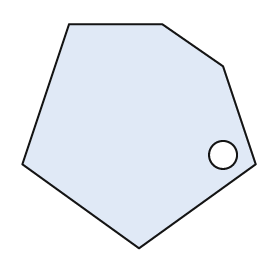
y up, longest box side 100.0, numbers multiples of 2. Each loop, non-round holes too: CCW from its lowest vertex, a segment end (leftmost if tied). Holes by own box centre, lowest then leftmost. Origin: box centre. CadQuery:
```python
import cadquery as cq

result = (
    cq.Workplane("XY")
    .moveTo(0.0, -48.0)
    .lineTo(50.0, -12.0)
    .lineTo(36.0, 30.0)
    .lineTo(10.0, 48.0)
    .lineTo(-30.0, 48.0)
    .lineTo(-50.0, -12.0)
    .close()
    .moveTo(36.0, -8.0)
    .circle(6.0)
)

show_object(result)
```